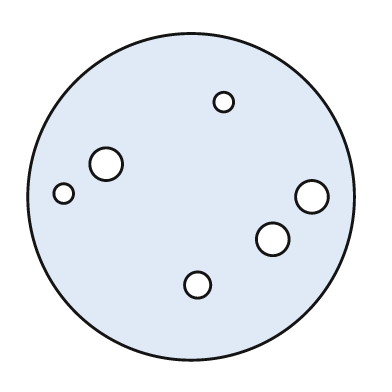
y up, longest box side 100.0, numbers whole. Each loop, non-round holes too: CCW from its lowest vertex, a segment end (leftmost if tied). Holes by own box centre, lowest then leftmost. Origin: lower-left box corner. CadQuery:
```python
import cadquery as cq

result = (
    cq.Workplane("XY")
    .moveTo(50.0, 50.0)
    .circle(50.0)
    .moveTo(52.0, 23.0)
    .circle(4.0)
    .moveTo(75.0, 37.0)
    .circle(5.0)
    .moveTo(87.0, 50.0)
    .circle(5.0)
    .moveTo(11.0, 51.0)
    .circle(3.0)
    .moveTo(24.0, 60.0)
    .circle(5.0)
    .moveTo(60.0, 79.0)
    .circle(3.0)
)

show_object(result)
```